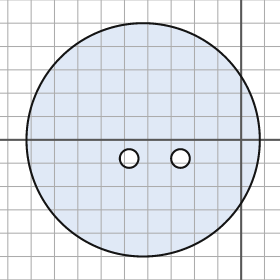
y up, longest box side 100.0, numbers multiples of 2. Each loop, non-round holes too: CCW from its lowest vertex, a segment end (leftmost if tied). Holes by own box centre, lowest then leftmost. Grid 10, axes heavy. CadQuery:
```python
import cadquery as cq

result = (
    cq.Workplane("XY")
    .moveTo(-42.0, 0.0)
    .circle(50.0)
    .moveTo(-48.0, -8.0)
    .circle(4.0)
    .moveTo(-26.0, -8.0)
    .circle(4.0)
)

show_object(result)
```